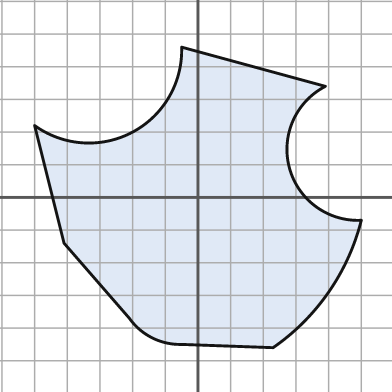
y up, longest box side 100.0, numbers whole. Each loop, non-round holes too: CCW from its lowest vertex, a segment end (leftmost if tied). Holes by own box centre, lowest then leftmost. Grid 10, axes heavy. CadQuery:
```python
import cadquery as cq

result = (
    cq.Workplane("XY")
    .moveTo(23.0, -46.0)
    .threePointArc((40.0, -29.0), (50.0, -7.0))
    .threePointArc((28.0, 9.0), (39.0, 34.0))
    .lineTo(-5.0, 46.0)
    .threePointArc((-20.0, 20.0), (-50.0, 22.0))
    .lineTo(-41.0, -14.0)
    .lineTo(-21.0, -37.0)
    .threePointArc((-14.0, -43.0), (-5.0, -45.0))
    .close()
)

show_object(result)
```